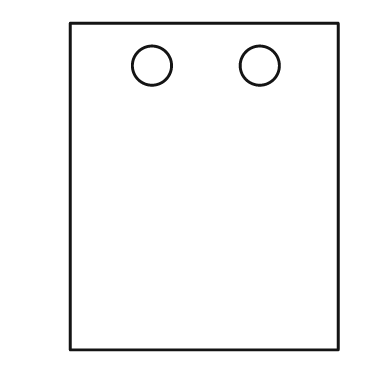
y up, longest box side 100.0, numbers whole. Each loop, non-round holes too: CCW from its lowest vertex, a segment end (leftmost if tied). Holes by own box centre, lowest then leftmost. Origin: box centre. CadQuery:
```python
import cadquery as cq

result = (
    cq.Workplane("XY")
    .moveTo(-41.0, -50.0)
    .lineTo(41.0, -50.0)
    .lineTo(41.0, 50.0)
    .lineTo(-41.0, 50.0)
    .close()
    .moveTo(-16.0, 37.0)
    .circle(6.0)
    .moveTo(17.0, 37.0)
    .circle(6.0)
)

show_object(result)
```